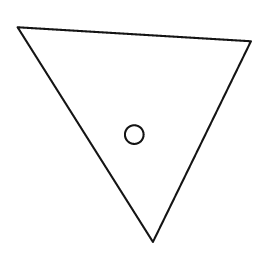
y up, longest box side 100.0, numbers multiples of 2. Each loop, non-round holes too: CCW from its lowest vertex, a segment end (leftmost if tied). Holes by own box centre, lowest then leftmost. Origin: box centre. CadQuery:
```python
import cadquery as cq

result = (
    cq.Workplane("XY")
    .moveTo(8.0, -46.0)
    .lineTo(50.0, 40.0)
    .lineTo(-50.0, 46.0)
    .close()
    .moveTo(0.0, 0.0)
    .circle(4.0)
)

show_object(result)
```